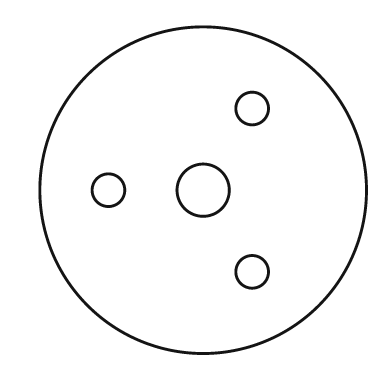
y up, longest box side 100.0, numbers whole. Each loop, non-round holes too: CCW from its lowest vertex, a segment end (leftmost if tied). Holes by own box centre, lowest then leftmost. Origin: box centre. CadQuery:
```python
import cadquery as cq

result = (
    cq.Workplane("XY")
    .moveTo(0.0, 0.0)
    .circle(50.0)
    .moveTo(15.0, -25.0)
    .circle(5.0)
    .moveTo(-29.0, 0.0)
    .circle(5.0)
    .moveTo(0.0, 0.0)
    .circle(8.0)
    .moveTo(15.0, 25.0)
    .circle(5.0)
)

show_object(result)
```